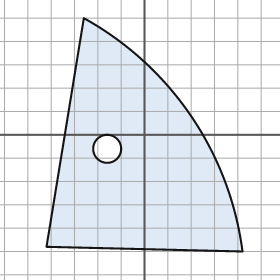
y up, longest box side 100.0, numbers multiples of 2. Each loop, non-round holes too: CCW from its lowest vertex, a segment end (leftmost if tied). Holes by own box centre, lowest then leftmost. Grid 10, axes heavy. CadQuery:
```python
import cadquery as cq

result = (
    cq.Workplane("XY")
    .moveTo(42.0, -50.0)
    .threePointArc((20.0, 8.0), (-26.0, 50.0))
    .lineTo(-42.0, -48.0)
    .close()
    .moveTo(-16.0, -6.0)
    .circle(6.0)
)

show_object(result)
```